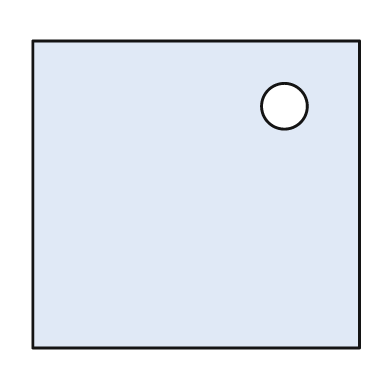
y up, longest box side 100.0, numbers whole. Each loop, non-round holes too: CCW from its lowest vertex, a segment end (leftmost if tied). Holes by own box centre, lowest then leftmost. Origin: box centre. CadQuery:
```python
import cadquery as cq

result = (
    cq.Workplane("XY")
    .moveTo(-50.0, -47.0)
    .lineTo(50.0, -47.0)
    .lineTo(50.0, 47.0)
    .lineTo(-50.0, 47.0)
    .close()
    .moveTo(27.0, 27.0)
    .circle(7.0)
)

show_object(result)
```